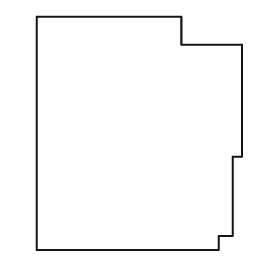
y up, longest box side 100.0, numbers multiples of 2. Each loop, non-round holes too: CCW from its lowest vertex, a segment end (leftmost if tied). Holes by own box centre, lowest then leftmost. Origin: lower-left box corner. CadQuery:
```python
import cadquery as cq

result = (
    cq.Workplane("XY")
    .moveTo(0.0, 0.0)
    .lineTo(78.0, 0.0)
    .lineTo(78.0, 6.0)
    .lineTo(84.0, 6.0)
    .lineTo(84.0, 40.0)
    .lineTo(88.0, 40.0)
    .lineTo(88.0, 88.0)
    .lineTo(62.0, 88.0)
    .lineTo(62.0, 100.0)
    .lineTo(0.0, 100.0)
    .close()
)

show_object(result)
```